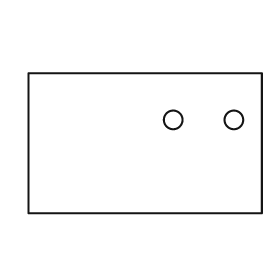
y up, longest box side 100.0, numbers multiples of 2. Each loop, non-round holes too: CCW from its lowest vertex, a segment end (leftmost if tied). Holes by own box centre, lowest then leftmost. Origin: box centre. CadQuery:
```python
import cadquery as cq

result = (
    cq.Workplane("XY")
    .moveTo(-50.0, -30.0)
    .lineTo(50.0, -30.0)
    .lineTo(50.0, 30.0)
    .lineTo(-50.0, 30.0)
    .close()
    .moveTo(12.0, 10.0)
    .circle(4.0)
    .moveTo(38.0, 10.0)
    .circle(4.0)
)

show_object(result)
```